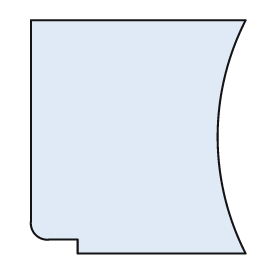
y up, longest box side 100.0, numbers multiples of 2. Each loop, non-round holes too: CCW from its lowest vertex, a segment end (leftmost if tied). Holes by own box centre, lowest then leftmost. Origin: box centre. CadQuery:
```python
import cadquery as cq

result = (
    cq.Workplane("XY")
    .moveTo(-26.0, -50.0)
    .lineTo(46.0, -50.0)
    .threePointArc((34.0, 0.0), (46.0, 50.0))
    .lineTo(-46.0, 50.0)
    .lineTo(-46.0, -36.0)
    .threePointArc((-44.0, -42.0), (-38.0, -44.0))
    .lineTo(-26.0, -44.0)
    .close()
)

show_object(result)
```